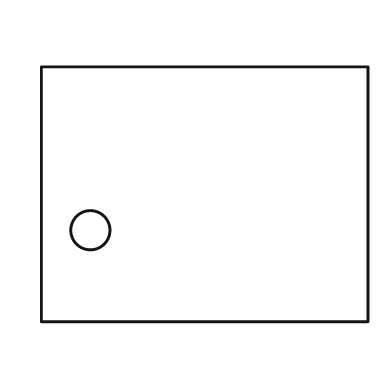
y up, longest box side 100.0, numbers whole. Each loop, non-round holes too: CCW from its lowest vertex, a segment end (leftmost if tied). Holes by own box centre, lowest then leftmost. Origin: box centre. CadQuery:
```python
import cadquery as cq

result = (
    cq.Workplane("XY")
    .moveTo(-50.0, -39.0)
    .lineTo(50.0, -39.0)
    .lineTo(50.0, 39.0)
    .lineTo(-50.0, 39.0)
    .close()
    .moveTo(-35.0, -11.0)
    .circle(6.0)
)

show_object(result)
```